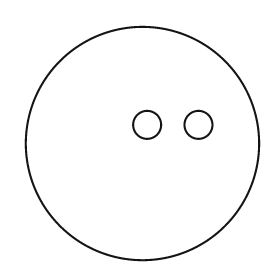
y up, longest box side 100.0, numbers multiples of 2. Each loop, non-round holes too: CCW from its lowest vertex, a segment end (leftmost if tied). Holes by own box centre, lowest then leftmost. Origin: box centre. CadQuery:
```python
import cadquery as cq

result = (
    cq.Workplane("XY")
    .moveTo(0.0, 0.0)
    .circle(50.0)
    .moveTo(2.0, 8.0)
    .circle(6.0)
    .moveTo(24.0, 8.0)
    .circle(6.0)
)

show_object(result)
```